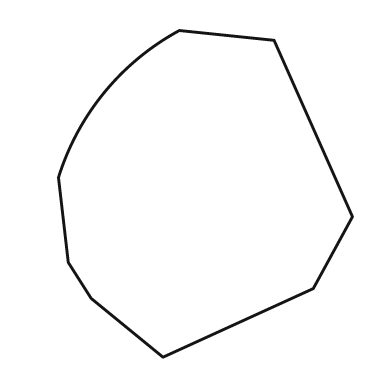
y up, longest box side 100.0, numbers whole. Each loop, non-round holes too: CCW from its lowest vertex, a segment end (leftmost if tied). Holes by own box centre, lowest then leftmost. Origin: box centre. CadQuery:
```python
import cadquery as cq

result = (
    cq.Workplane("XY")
    .moveTo(-13.0, -50.0)
    .lineTo(33.0, -29.0)
    .lineTo(45.0, -7.0)
    .lineTo(21.0, 47.0)
    .lineTo(-8.0, 50.0)
    .threePointArc((-31.0, 31.0), (-45.0, 5.0))
    .lineTo(-42.0, -21.0)
    .lineTo(-35.0, -32.0)
    .close()
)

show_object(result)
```